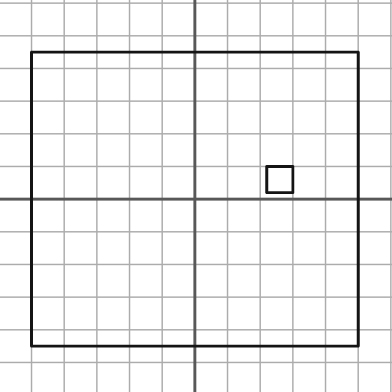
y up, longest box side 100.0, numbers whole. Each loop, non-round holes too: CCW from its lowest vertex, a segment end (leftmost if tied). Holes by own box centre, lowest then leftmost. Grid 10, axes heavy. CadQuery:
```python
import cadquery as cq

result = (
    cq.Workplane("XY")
    .moveTo(-50.0, -45.0)
    .lineTo(50.0, -45.0)
    .lineTo(50.0, 45.0)
    .lineTo(-50.0, 45.0)
    .close()
    .moveTo(22.0, 2.0)
    .lineTo(30.0, 2.0)
    .lineTo(30.0, 10.0)
    .lineTo(22.0, 10.0)
    .close()
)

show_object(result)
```